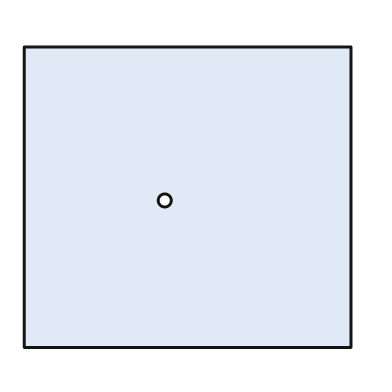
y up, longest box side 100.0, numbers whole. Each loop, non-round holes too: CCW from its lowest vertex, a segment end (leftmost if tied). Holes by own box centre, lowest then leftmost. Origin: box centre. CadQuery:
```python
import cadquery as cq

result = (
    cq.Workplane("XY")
    .moveTo(-50.0, -46.0)
    .lineTo(50.0, -46.0)
    .lineTo(50.0, 46.0)
    .lineTo(-50.0, 46.0)
    .close()
    .moveTo(-7.0, -1.0)
    .circle(2.0)
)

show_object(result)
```